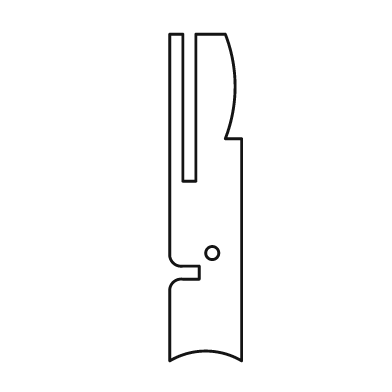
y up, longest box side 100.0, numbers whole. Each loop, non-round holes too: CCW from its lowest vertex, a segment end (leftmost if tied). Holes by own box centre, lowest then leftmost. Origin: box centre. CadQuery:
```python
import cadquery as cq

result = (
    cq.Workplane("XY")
    .moveTo(-11.0, -50.0)
    .threePointArc((0.0, -47.0), (11.0, -50.0))
    .lineTo(11.0, 18.0)
    .lineTo(6.0, 18.0)
    .threePointArc((9.0, 34.0), (6.0, 50.0))
    .lineTo(-3.0, 50.0)
    .lineTo(-3.0, 5.0)
    .lineTo(-7.0, 5.0)
    .lineTo(-7.0, 50.0)
    .lineTo(-11.0, 50.0)
    .lineTo(-11.0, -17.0)
    .threePointArc((-10.0, -20.0), (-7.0, -21.0))
    .lineTo(-2.0, -21.0)
    .lineTo(-2.0, -25.0)
    .lineTo(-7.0, -25.0)
    .threePointArc((-10.0, -26.0), (-11.0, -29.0))
    .close()
    .moveTo(2.0, -17.0)
    .circle(2.0)
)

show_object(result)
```